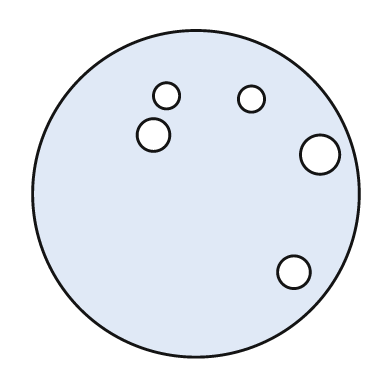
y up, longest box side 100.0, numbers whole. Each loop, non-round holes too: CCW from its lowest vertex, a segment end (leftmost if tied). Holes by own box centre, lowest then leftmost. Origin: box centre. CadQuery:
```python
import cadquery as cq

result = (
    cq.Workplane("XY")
    .moveTo(0.0, 0.0)
    .circle(50.0)
    .moveTo(30.0, -24.0)
    .circle(5.0)
    .moveTo(38.0, 12.0)
    .circle(6.0)
    .moveTo(-13.0, 18.0)
    .circle(5.0)
    .moveTo(17.0, 29.0)
    .circle(4.0)
    .moveTo(-9.0, 30.0)
    .circle(4.0)
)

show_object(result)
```